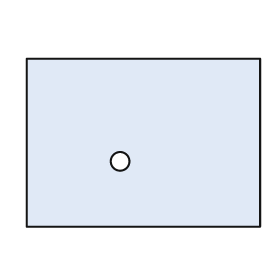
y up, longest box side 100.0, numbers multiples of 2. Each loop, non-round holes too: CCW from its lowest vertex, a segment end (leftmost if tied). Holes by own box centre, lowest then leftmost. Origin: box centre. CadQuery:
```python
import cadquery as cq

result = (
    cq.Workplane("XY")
    .moveTo(-50.0, -36.0)
    .lineTo(50.0, -36.0)
    .lineTo(50.0, 36.0)
    .lineTo(-50.0, 36.0)
    .close()
    .moveTo(-10.0, -8.0)
    .circle(4.0)
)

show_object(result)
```